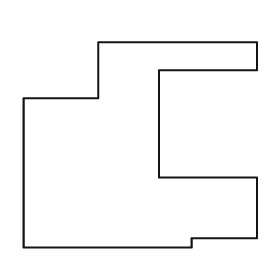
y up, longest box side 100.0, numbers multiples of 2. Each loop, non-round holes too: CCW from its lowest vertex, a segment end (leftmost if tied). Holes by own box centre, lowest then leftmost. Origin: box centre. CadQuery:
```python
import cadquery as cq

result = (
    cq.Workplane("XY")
    .moveTo(-50.0, -44.0)
    .lineTo(22.0, -44.0)
    .lineTo(22.0, -40.0)
    .lineTo(50.0, -40.0)
    .lineTo(50.0, -14.0)
    .lineTo(8.0, -14.0)
    .lineTo(8.0, 32.0)
    .lineTo(50.0, 32.0)
    .lineTo(50.0, 44.0)
    .lineTo(-18.0, 44.0)
    .lineTo(-18.0, 20.0)
    .lineTo(-50.0, 20.0)
    .close()
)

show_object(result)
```